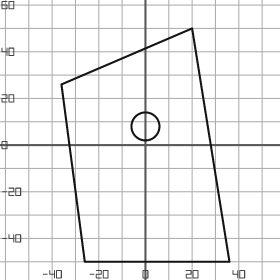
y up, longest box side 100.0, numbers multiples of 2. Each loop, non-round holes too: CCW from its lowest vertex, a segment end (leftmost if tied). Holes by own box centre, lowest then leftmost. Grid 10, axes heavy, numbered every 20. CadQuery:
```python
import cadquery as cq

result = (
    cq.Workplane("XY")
    .moveTo(-26.0, -50.0)
    .lineTo(36.0, -50.0)
    .lineTo(20.0, 50.0)
    .lineTo(-36.0, 26.0)
    .close()
    .moveTo(0.0, 8.0)
    .circle(6.0)
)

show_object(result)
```